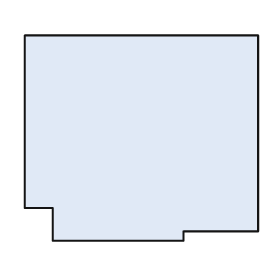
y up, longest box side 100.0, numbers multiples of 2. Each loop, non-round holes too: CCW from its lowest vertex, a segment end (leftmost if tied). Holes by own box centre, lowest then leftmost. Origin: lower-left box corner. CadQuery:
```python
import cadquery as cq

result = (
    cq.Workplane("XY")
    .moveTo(12.0, 0.0)
    .lineTo(68.0, 0.0)
    .lineTo(68.0, 4.0)
    .lineTo(100.0, 4.0)
    .lineTo(100.0, 88.0)
    .lineTo(0.0, 88.0)
    .lineTo(0.0, 14.0)
    .lineTo(12.0, 14.0)
    .close()
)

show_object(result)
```